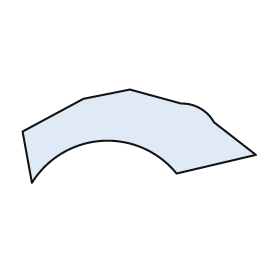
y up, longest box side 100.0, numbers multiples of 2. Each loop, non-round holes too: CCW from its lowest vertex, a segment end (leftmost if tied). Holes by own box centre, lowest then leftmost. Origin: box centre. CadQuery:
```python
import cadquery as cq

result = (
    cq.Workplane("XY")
    .moveTo(-46.0, -20.0)
    .threePointArc((-16.0, -2.0), (16.0, -16.0))
    .lineTo(50.0, -8.0)
    .lineTo(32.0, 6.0)
    .threePointArc((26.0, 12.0), (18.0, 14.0))
    .lineTo(-4.0, 20.0)
    .lineTo(-24.0, 16.0)
    .lineTo(-50.0, 2.0)
    .close()
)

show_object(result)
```